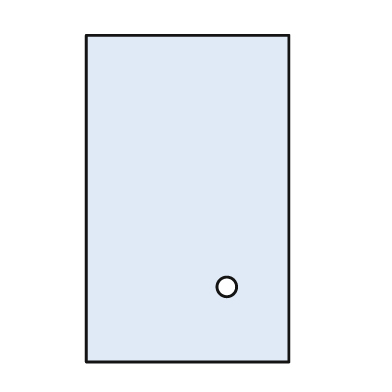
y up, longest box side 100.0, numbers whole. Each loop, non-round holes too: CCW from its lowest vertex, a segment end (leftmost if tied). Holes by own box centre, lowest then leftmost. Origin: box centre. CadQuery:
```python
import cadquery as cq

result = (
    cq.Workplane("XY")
    .moveTo(-31.0, -50.0)
    .lineTo(31.0, -50.0)
    .lineTo(31.0, 50.0)
    .lineTo(-31.0, 50.0)
    .close()
    .moveTo(12.0, -27.0)
    .circle(3.0)
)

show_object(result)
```